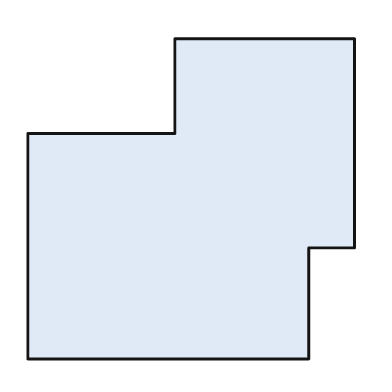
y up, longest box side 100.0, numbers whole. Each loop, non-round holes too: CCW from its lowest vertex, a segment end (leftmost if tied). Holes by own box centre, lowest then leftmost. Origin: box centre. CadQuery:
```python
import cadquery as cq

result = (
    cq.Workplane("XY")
    .moveTo(-50.0, -49.0)
    .lineTo(36.0, -49.0)
    .lineTo(36.0, -15.0)
    .lineTo(50.0, -15.0)
    .lineTo(50.0, 49.0)
    .lineTo(-5.0, 49.0)
    .lineTo(-5.0, 20.0)
    .lineTo(-50.0, 20.0)
    .close()
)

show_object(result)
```